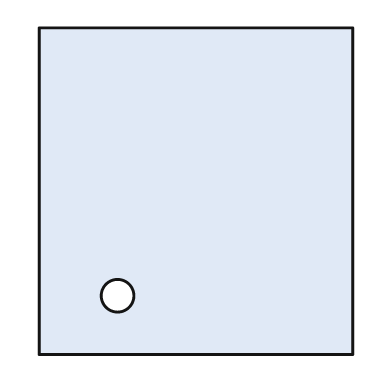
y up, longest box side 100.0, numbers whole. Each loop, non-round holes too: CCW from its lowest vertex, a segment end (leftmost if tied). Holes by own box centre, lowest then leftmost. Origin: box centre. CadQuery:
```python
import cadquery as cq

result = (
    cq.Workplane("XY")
    .moveTo(-48.0, -50.0)
    .lineTo(48.0, -50.0)
    .lineTo(48.0, 50.0)
    .lineTo(-48.0, 50.0)
    .close()
    .moveTo(-24.0, -32.0)
    .circle(5.0)
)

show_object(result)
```